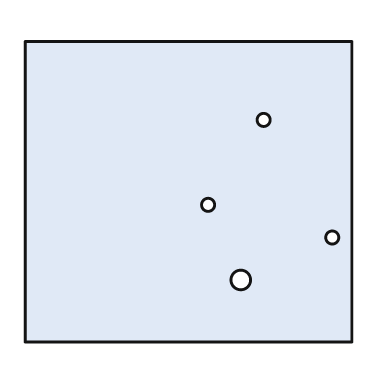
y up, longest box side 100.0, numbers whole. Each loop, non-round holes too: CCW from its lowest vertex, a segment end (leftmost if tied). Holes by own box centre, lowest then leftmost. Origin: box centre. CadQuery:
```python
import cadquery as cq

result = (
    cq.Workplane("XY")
    .moveTo(-50.0, -46.0)
    .lineTo(50.0, -46.0)
    .lineTo(50.0, 46.0)
    .lineTo(-50.0, 46.0)
    .close()
    .moveTo(16.0, -27.0)
    .circle(3.0)
    .moveTo(44.0, -14.0)
    .circle(2.0)
    .moveTo(6.0, -4.0)
    .circle(2.0)
    .moveTo(23.0, 22.0)
    .circle(2.0)
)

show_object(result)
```